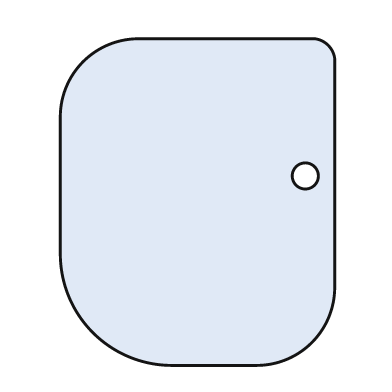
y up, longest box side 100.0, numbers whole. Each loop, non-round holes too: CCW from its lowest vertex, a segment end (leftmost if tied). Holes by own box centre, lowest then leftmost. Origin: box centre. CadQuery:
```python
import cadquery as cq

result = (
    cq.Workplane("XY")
    .moveTo(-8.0, -50.0)
    .lineTo(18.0, -50.0)
    .threePointArc((35.0, -43.0), (42.0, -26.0))
    .lineTo(42.0, 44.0)
    .threePointArc((40.0, 48.0), (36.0, 50.0))
    .lineTo(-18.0, 50.0)
    .threePointArc((-35.0, 43.0), (-42.0, 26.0))
    .lineTo(-42.0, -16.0)
    .threePointArc((-32.0, -40.0), (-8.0, -50.0))
    .close()
    .moveTo(33.0, 8.0)
    .circle(4.0)
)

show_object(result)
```